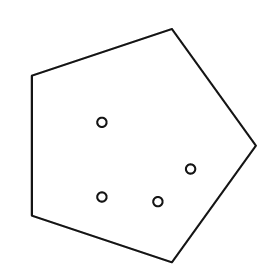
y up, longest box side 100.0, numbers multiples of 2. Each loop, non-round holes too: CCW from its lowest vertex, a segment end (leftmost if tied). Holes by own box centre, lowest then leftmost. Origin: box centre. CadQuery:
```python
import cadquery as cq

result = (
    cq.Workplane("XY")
    .moveTo(12.0, -50.0)
    .lineTo(48.0, 0.0)
    .lineTo(12.0, 50.0)
    .lineTo(-48.0, 30.0)
    .lineTo(-48.0, -30.0)
    .close()
    .moveTo(6.0, -24.0)
    .circle(2.0)
    .moveTo(-18.0, -22.0)
    .circle(2.0)
    .moveTo(20.0, -10.0)
    .circle(2.0)
    .moveTo(-18.0, 10.0)
    .circle(2.0)
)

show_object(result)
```